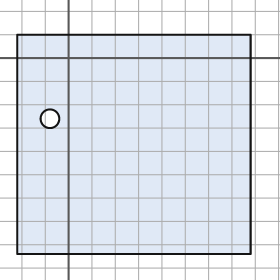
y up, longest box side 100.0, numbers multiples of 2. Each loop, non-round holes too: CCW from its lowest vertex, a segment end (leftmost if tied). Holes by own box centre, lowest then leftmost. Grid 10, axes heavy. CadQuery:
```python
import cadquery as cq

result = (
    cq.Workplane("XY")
    .moveTo(-22.0, -84.0)
    .lineTo(78.0, -84.0)
    .lineTo(78.0, 10.0)
    .lineTo(-22.0, 10.0)
    .close()
    .moveTo(-8.0, -26.0)
    .circle(4.0)
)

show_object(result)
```